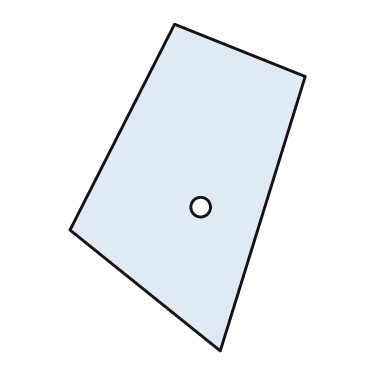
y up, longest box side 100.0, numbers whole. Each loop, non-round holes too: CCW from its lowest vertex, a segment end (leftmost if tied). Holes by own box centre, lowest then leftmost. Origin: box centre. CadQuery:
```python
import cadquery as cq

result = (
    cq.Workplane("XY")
    .moveTo(10.0, -50.0)
    .lineTo(36.0, 34.0)
    .lineTo(-4.0, 50.0)
    .lineTo(-36.0, -13.0)
    .close()
    .moveTo(4.0, -6.0)
    .circle(3.0)
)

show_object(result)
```